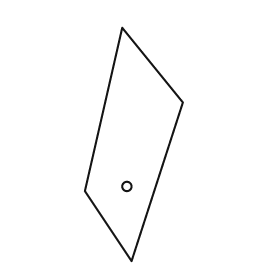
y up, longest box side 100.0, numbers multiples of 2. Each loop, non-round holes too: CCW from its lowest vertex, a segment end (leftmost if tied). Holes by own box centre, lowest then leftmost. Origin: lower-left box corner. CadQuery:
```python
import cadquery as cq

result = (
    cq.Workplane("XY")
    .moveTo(20.0, 0.0)
    .lineTo(42.0, 68.0)
    .lineTo(16.0, 100.0)
    .lineTo(0.0, 30.0)
    .close()
    .moveTo(18.0, 32.0)
    .circle(2.0)
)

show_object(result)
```